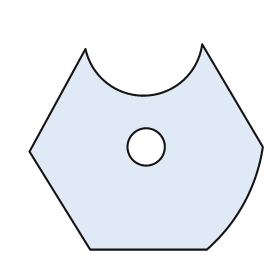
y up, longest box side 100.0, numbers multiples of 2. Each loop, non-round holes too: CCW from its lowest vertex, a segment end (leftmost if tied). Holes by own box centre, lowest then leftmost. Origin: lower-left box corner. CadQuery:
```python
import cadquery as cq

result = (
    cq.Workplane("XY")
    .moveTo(26.0, 0.0)
    .lineTo(76.0, 0.0)
    .threePointArc((92.0, 20.0), (100.0, 44.0))
    .lineTo(74.0, 88.0)
    .threePointArc((50.0, 66.0), (24.0, 86.0))
    .lineTo(0.0, 42.0)
    .close()
    .moveTo(50.0, 44.0)
    .circle(8.0)
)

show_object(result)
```